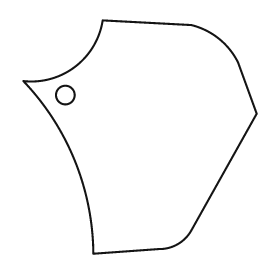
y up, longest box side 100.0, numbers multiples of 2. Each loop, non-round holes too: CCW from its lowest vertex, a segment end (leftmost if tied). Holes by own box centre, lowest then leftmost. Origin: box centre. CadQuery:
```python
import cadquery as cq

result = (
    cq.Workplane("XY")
    .moveTo(-20.0, -50.0)
    .lineTo(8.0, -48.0)
    .threePointArc((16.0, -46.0), (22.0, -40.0))
    .lineTo(50.0, 10.0)
    .lineTo(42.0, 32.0)
    .threePointArc((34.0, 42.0), (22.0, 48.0))
    .lineTo(-16.0, 50.0)
    .threePointArc((-28.0, 30.0), (-50.0, 24.0))
    .threePointArc((-28.0, -10.0), (-20.0, -50.0))
    .close()
    .moveTo(-32.0, 18.0)
    .circle(4.0)
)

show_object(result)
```